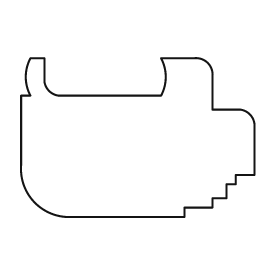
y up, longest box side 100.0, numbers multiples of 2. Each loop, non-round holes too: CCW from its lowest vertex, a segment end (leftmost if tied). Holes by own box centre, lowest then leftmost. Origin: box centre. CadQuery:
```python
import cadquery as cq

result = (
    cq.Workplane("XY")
    .moveTo(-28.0, -34.0)
    .lineTo(20.0, -34.0)
    .lineTo(20.0, -30.0)
    .lineTo(32.0, -30.0)
    .lineTo(32.0, -26.0)
    .lineTo(38.0, -26.0)
    .lineTo(38.0, -20.0)
    .lineTo(42.0, -20.0)
    .lineTo(42.0, -16.0)
    .lineTo(50.0, -16.0)
    .lineTo(50.0, 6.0)
    .threePointArc((48.0, 10.0), (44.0, 12.0))
    .lineTo(32.0, 12.0)
    .lineTo(32.0, 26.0)
    .threePointArc((30.0, 32.0), (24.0, 34.0))
    .lineTo(10.0, 34.0)
    .threePointArc((12.0, 26.0), (10.0, 18.0))
    .lineTo(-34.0, 18.0)
    .threePointArc((-38.0, 20.0), (-40.0, 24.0))
    .lineTo(-40.0, 34.0)
    .lineTo(-46.0, 34.0)
    .threePointArc((-48.0, 26.0), (-46.0, 18.0))
    .lineTo(-50.0, 18.0)
    .lineTo(-50.0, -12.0)
    .threePointArc((-44.0, -28.0), (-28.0, -34.0))
    .close()
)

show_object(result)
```